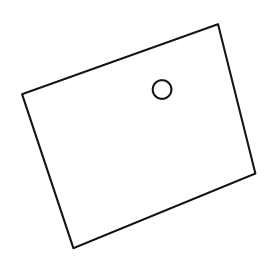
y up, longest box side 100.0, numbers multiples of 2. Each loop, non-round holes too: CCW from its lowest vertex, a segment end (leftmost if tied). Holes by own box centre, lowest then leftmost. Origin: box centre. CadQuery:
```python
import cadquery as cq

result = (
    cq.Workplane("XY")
    .moveTo(-28.0, -48.0)
    .lineTo(50.0, -16.0)
    .lineTo(34.0, 48.0)
    .lineTo(-50.0, 18.0)
    .close()
    .moveTo(10.0, 20.0)
    .circle(4.0)
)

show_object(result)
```